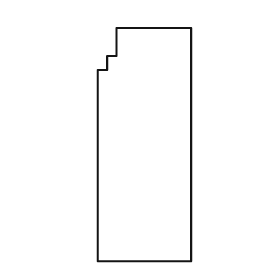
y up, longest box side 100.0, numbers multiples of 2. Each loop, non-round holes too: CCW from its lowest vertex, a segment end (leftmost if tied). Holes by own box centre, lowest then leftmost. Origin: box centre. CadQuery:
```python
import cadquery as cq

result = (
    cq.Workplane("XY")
    .moveTo(-20.0, -50.0)
    .lineTo(20.0, -50.0)
    .lineTo(20.0, 50.0)
    .lineTo(-12.0, 50.0)
    .lineTo(-12.0, 38.0)
    .lineTo(-16.0, 38.0)
    .lineTo(-16.0, 32.0)
    .lineTo(-20.0, 32.0)
    .close()
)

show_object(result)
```